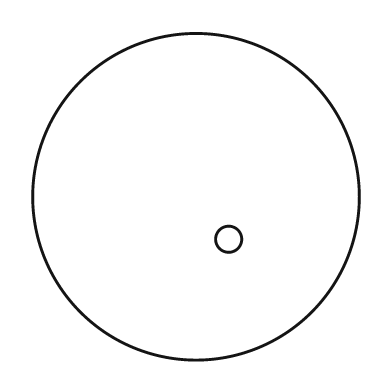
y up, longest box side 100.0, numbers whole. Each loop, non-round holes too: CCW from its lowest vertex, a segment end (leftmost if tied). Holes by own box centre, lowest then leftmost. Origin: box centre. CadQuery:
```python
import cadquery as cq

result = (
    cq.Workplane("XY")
    .moveTo(0.0, 0.0)
    .circle(50.0)
    .moveTo(10.0, -13.0)
    .circle(4.0)
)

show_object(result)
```